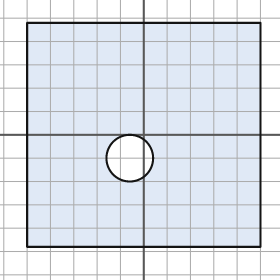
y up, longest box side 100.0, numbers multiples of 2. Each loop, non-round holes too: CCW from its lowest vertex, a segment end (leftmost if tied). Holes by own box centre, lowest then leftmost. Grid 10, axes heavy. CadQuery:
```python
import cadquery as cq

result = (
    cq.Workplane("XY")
    .moveTo(-50.0, -48.0)
    .lineTo(50.0, -48.0)
    .lineTo(50.0, 48.0)
    .lineTo(-50.0, 48.0)
    .close()
    .moveTo(-6.0, -10.0)
    .circle(10.0)
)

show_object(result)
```